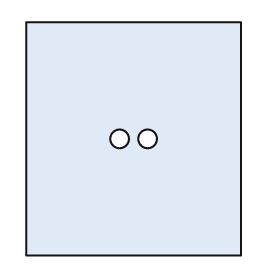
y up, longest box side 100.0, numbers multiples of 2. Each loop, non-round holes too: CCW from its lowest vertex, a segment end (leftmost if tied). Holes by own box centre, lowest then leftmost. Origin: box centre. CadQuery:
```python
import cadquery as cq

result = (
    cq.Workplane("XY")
    .moveTo(-46.0, -50.0)
    .lineTo(46.0, -50.0)
    .lineTo(46.0, 50.0)
    .lineTo(-46.0, 50.0)
    .close()
    .moveTo(-6.0, 0.0)
    .circle(4.0)
    .moveTo(6.0, 0.0)
    .circle(4.0)
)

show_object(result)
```